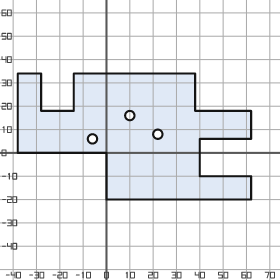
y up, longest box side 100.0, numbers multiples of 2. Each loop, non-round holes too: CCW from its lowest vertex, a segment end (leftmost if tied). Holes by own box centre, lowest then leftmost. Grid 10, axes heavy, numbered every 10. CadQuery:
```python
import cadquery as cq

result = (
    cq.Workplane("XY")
    .moveTo(0.0, -20.0)
    .lineTo(62.0, -20.0)
    .lineTo(62.0, -10.0)
    .lineTo(40.0, -10.0)
    .lineTo(40.0, 6.0)
    .lineTo(62.0, 6.0)
    .lineTo(62.0, 18.0)
    .lineTo(38.0, 18.0)
    .lineTo(38.0, 34.0)
    .lineTo(-14.0, 34.0)
    .lineTo(-14.0, 18.0)
    .lineTo(-28.0, 18.0)
    .lineTo(-28.0, 34.0)
    .lineTo(-38.0, 34.0)
    .lineTo(-38.0, 0.0)
    .lineTo(0.0, 0.0)
    .close()
    .moveTo(-6.0, 6.0)
    .circle(2.0)
    .moveTo(22.0, 8.0)
    .circle(2.0)
    .moveTo(10.0, 16.0)
    .circle(2.0)
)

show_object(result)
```